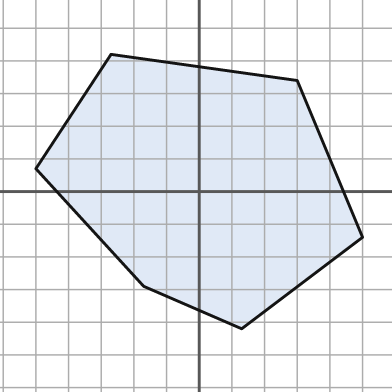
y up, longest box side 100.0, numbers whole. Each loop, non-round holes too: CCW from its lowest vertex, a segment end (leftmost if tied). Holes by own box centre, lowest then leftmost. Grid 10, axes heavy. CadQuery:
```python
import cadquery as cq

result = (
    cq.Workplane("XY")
    .moveTo(13.0, -42.0)
    .lineTo(50.0, -14.0)
    .lineTo(30.0, 34.0)
    .lineTo(-27.0, 42.0)
    .lineTo(-50.0, 7.0)
    .lineTo(-17.0, -29.0)
    .close()
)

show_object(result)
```